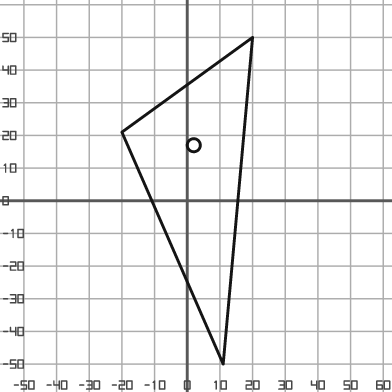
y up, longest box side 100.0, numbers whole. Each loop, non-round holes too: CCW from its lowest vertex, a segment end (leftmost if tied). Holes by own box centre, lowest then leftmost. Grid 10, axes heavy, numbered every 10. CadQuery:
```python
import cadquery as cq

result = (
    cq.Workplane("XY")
    .moveTo(11.0, -50.0)
    .lineTo(20.0, 50.0)
    .lineTo(-20.0, 21.0)
    .close()
    .moveTo(2.0, 17.0)
    .circle(2.0)
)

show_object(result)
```